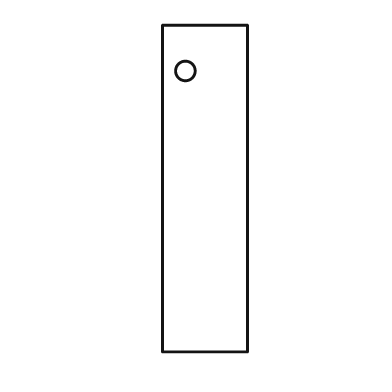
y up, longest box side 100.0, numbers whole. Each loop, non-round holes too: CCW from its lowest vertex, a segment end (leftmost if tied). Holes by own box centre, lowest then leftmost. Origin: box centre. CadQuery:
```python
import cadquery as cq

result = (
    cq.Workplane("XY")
    .moveTo(-13.0, -50.0)
    .lineTo(13.0, -50.0)
    .lineTo(13.0, 50.0)
    .lineTo(-13.0, 50.0)
    .close()
    .moveTo(-6.0, 36.0)
    .circle(3.0)
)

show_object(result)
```